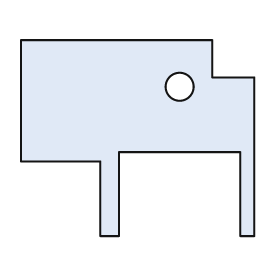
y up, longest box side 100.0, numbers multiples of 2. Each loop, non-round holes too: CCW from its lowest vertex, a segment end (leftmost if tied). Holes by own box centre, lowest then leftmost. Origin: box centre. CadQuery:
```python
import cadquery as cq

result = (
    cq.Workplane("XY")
    .moveTo(-16.0, -42.0)
    .lineTo(-8.0, -42.0)
    .lineTo(-8.0, -6.0)
    .lineTo(44.0, -6.0)
    .lineTo(44.0, -42.0)
    .lineTo(50.0, -42.0)
    .lineTo(50.0, 26.0)
    .lineTo(32.0, 26.0)
    .lineTo(32.0, 42.0)
    .lineTo(-50.0, 42.0)
    .lineTo(-50.0, -10.0)
    .lineTo(-16.0, -10.0)
    .close()
    .moveTo(18.0, 22.0)
    .circle(6.0)
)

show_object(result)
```